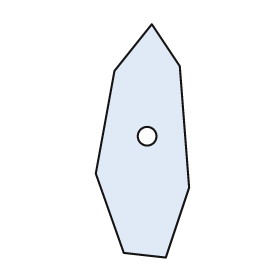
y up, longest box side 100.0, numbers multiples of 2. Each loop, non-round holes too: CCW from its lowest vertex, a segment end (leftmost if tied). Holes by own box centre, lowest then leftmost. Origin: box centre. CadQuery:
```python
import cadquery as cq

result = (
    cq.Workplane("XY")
    .moveTo(10.0, -50.0)
    .lineTo(20.0, -20.0)
    .lineTo(16.0, 32.0)
    .lineTo(4.0, 50.0)
    .lineTo(-12.0, 30.0)
    .lineTo(-20.0, -14.0)
    .lineTo(-8.0, -48.0)
    .close()
    .moveTo(2.0, 2.0)
    .circle(4.0)
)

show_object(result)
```